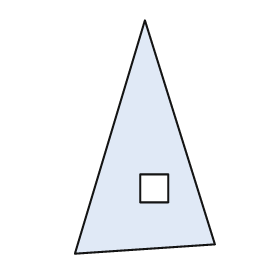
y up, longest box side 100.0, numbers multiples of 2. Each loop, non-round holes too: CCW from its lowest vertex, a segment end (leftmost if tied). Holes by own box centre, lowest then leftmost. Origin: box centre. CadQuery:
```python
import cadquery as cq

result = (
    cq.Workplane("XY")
    .moveTo(-30.0, -50.0)
    .lineTo(30.0, -46.0)
    .lineTo(0.0, 50.0)
    .close()
    .moveTo(-2.0, -28.0)
    .lineTo(10.0, -28.0)
    .lineTo(10.0, -16.0)
    .lineTo(-2.0, -16.0)
    .close()
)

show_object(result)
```